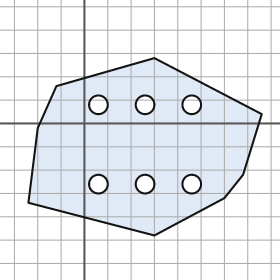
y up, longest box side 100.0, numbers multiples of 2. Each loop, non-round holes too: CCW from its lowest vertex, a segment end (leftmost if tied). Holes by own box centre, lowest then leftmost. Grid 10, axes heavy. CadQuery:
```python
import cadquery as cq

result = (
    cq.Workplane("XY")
    .moveTo(30.0, -48.0)
    .lineTo(60.0, -32.0)
    .lineTo(68.0, -22.0)
    .lineTo(76.0, 4.0)
    .lineTo(30.0, 28.0)
    .lineTo(-12.0, 16.0)
    .lineTo(-20.0, -2.0)
    .lineTo(-24.0, -34.0)
    .close()
    .moveTo(6.0, -26.0)
    .circle(4.0)
    .moveTo(26.0, -26.0)
    .circle(4.0)
    .moveTo(46.0, -26.0)
    .circle(4.0)
    .moveTo(6.0, 8.0)
    .circle(4.0)
    .moveTo(26.0, 8.0)
    .circle(4.0)
    .moveTo(46.0, 8.0)
    .circle(4.0)
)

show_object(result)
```